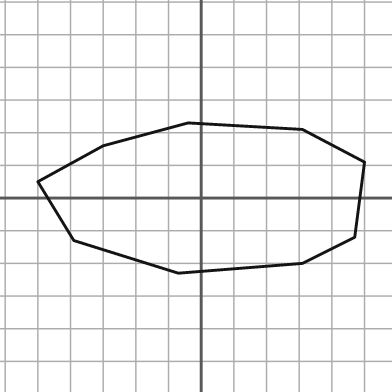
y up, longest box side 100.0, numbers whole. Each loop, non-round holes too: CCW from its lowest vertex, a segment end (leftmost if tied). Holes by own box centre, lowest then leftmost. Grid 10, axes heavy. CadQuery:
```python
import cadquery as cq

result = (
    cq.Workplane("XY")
    .moveTo(-7.0, -23.0)
    .lineTo(31.0, -20.0)
    .lineTo(47.0, -12.0)
    .lineTo(50.0, 11.0)
    .lineTo(31.0, 21.0)
    .lineTo(-4.0, 23.0)
    .lineTo(-30.0, 16.0)
    .lineTo(-50.0, 5.0)
    .lineTo(-39.0, -13.0)
    .close()
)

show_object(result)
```